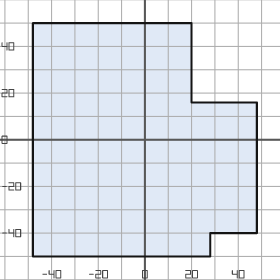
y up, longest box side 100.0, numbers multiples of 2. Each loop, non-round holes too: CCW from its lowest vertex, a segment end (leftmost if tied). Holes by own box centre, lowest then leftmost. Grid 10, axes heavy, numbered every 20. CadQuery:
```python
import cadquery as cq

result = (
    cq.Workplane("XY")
    .moveTo(-48.0, -50.0)
    .lineTo(28.0, -50.0)
    .lineTo(28.0, -40.0)
    .lineTo(48.0, -40.0)
    .lineTo(48.0, 16.0)
    .lineTo(20.0, 16.0)
    .lineTo(20.0, 50.0)
    .lineTo(-48.0, 50.0)
    .close()
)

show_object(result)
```